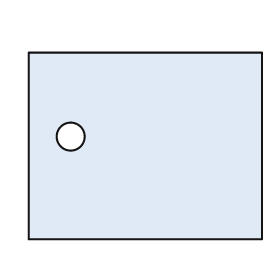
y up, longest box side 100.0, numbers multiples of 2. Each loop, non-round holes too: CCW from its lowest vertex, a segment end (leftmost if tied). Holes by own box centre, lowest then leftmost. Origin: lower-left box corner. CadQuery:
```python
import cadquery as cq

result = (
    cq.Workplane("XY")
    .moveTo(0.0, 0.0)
    .lineTo(100.0, 0.0)
    .lineTo(100.0, 80.0)
    .lineTo(0.0, 80.0)
    .close()
    .moveTo(18.0, 44.0)
    .circle(6.0)
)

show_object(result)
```